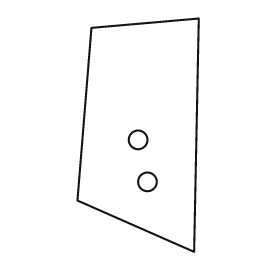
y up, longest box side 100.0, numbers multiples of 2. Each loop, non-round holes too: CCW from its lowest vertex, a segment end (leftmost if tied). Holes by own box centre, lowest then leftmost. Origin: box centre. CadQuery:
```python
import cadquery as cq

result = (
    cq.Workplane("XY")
    .moveTo(24.0, -50.0)
    .lineTo(26.0, 50.0)
    .lineTo(-20.0, 46.0)
    .lineTo(-26.0, -28.0)
    .close()
    .moveTo(4.0, -20.0)
    .circle(4.0)
    .moveTo(0.0, -2.0)
    .circle(4.0)
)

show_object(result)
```